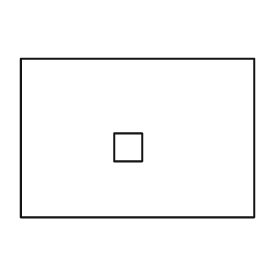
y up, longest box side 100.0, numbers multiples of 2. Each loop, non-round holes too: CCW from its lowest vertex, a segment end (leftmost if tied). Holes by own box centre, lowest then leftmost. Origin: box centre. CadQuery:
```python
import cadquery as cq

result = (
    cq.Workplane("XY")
    .moveTo(-50.0, -34.0)
    .lineTo(50.0, -34.0)
    .lineTo(50.0, 34.0)
    .lineTo(-50.0, 34.0)
    .close()
    .moveTo(-10.0, -10.0)
    .lineTo(2.0, -10.0)
    .lineTo(2.0, 2.0)
    .lineTo(-10.0, 2.0)
    .close()
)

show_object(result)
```